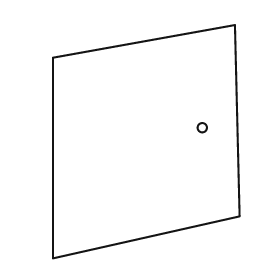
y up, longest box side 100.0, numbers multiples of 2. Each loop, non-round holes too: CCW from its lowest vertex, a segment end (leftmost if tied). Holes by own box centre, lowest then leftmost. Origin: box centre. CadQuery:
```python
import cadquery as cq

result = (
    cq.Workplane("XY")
    .moveTo(-40.0, -50.0)
    .lineTo(40.0, -32.0)
    .lineTo(38.0, 50.0)
    .lineTo(-40.0, 36.0)
    .close()
    .moveTo(24.0, 6.0)
    .circle(2.0)
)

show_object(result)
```